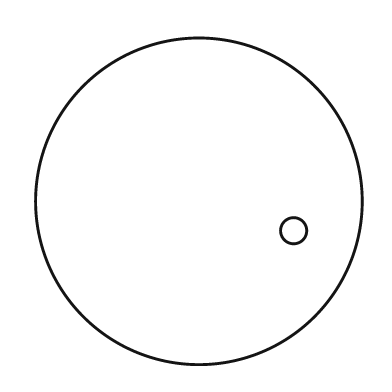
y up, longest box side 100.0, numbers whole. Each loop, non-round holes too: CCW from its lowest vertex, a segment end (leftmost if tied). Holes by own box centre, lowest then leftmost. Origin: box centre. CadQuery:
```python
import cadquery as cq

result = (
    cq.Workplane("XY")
    .moveTo(0.0, 0.0)
    .circle(50.0)
    .moveTo(29.0, -9.0)
    .circle(4.0)
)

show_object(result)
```